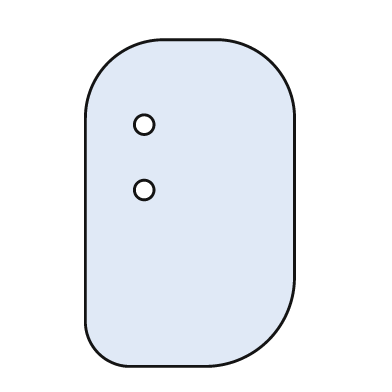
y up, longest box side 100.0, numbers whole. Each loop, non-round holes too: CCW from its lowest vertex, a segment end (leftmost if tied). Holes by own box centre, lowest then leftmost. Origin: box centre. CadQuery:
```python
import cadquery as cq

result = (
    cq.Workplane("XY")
    .moveTo(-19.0, -50.0)
    .lineTo(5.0, -50.0)
    .threePointArc((24.0, -42.0), (32.0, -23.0))
    .lineTo(32.0, 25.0)
    .threePointArc((25.0, 43.0), (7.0, 50.0))
    .lineTo(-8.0, 50.0)
    .threePointArc((-25.0, 43.0), (-32.0, 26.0))
    .lineTo(-32.0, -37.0)
    .threePointArc((-28.0, -46.0), (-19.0, -50.0))
    .close()
    .moveTo(-14.0, 4.0)
    .circle(3.0)
    .moveTo(-14.0, 24.0)
    .circle(3.0)
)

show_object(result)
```